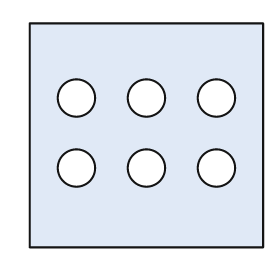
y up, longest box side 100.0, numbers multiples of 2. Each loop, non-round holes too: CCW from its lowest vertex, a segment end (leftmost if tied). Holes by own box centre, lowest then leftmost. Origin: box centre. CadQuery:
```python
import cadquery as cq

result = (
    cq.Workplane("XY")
    .moveTo(-50.0, -48.0)
    .lineTo(50.0, -48.0)
    .lineTo(50.0, 48.0)
    .lineTo(-50.0, 48.0)
    .close()
    .moveTo(-30.0, -14.0)
    .circle(8.0)
    .moveTo(0.0, -14.0)
    .circle(8.0)
    .moveTo(30.0, -14.0)
    .circle(8.0)
    .moveTo(-30.0, 16.0)
    .circle(8.0)
    .moveTo(0.0, 16.0)
    .circle(8.0)
    .moveTo(30.0, 16.0)
    .circle(8.0)
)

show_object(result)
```